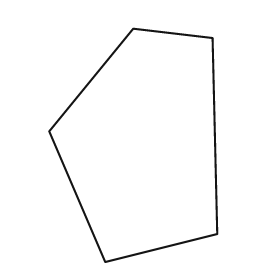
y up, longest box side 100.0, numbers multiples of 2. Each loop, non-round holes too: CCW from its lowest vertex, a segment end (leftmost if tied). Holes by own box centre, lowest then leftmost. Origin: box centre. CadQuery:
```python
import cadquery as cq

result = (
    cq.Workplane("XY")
    .moveTo(-12.0, -50.0)
    .lineTo(36.0, -38.0)
    .lineTo(34.0, 46.0)
    .lineTo(0.0, 50.0)
    .lineTo(-36.0, 6.0)
    .close()
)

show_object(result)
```